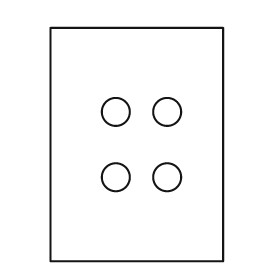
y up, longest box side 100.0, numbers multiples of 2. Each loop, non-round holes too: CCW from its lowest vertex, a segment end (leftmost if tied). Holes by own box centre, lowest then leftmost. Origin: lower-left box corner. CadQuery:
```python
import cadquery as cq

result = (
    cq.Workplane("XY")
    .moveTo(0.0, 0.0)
    .lineTo(74.0, 0.0)
    .lineTo(74.0, 100.0)
    .lineTo(0.0, 100.0)
    .close()
    .moveTo(28.0, 36.0)
    .circle(6.0)
    .moveTo(50.0, 36.0)
    .circle(6.0)
    .moveTo(28.0, 64.0)
    .circle(6.0)
    .moveTo(50.0, 64.0)
    .circle(6.0)
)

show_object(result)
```